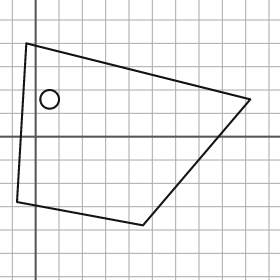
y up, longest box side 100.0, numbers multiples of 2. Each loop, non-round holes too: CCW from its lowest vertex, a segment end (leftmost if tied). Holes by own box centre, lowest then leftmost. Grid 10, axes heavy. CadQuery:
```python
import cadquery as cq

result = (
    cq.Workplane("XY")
    .moveTo(46.0, -38.0)
    .lineTo(92.0, 16.0)
    .lineTo(-4.0, 40.0)
    .lineTo(-8.0, -28.0)
    .close()
    .moveTo(6.0, 16.0)
    .circle(4.0)
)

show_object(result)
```